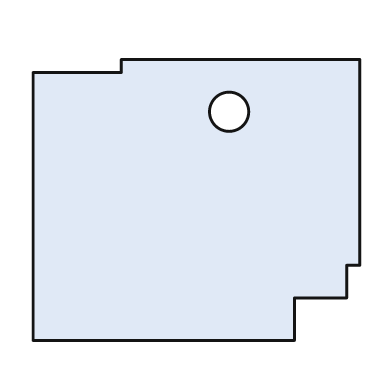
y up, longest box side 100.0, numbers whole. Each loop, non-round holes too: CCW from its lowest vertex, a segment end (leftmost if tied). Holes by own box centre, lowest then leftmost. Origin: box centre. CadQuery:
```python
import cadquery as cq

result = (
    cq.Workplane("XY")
    .moveTo(-50.0, -43.0)
    .lineTo(30.0, -43.0)
    .lineTo(30.0, -30.0)
    .lineTo(46.0, -30.0)
    .lineTo(46.0, -20.0)
    .lineTo(50.0, -20.0)
    .lineTo(50.0, 43.0)
    .lineTo(-23.0, 43.0)
    .lineTo(-23.0, 39.0)
    .lineTo(-50.0, 39.0)
    .close()
    .moveTo(10.0, 27.0)
    .circle(6.0)
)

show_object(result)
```